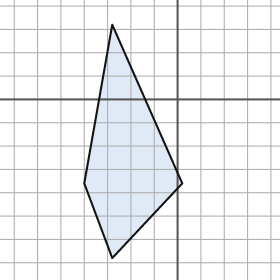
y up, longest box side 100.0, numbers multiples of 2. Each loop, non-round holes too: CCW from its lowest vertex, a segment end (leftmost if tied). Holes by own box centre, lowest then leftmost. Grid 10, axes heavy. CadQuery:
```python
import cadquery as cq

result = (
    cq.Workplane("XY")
    .moveTo(-28.0, -68.0)
    .lineTo(2.0, -36.0)
    .lineTo(-28.0, 32.0)
    .lineTo(-40.0, -36.0)
    .close()
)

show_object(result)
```